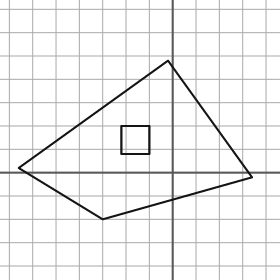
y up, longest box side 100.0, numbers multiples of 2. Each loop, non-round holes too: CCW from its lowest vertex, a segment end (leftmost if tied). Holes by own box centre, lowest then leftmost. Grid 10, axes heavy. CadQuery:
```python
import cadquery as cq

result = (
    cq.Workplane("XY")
    .moveTo(-30.0, -20.0)
    .lineTo(34.0, -2.0)
    .lineTo(-2.0, 48.0)
    .lineTo(-66.0, 2.0)
    .close()
    .moveTo(-22.0, 8.0)
    .lineTo(-10.0, 8.0)
    .lineTo(-10.0, 20.0)
    .lineTo(-22.0, 20.0)
    .close()
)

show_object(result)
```